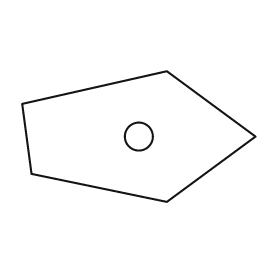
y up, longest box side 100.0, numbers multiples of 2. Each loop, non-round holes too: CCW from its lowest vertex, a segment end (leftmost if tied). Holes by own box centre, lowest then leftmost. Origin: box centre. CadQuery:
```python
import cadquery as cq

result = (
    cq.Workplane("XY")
    .moveTo(12.0, -28.0)
    .lineTo(50.0, 0.0)
    .lineTo(12.0, 28.0)
    .lineTo(-50.0, 14.0)
    .lineTo(-46.0, -16.0)
    .close()
    .moveTo(0.0, 0.0)
    .circle(6.0)
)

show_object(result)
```